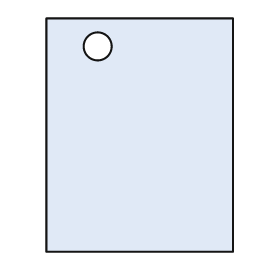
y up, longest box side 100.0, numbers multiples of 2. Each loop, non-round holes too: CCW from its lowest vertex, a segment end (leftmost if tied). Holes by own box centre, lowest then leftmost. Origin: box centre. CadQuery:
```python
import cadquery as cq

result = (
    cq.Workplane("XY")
    .moveTo(-40.0, -50.0)
    .lineTo(40.0, -50.0)
    .lineTo(40.0, 50.0)
    .lineTo(-40.0, 50.0)
    .close()
    .moveTo(-18.0, 38.0)
    .circle(6.0)
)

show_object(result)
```